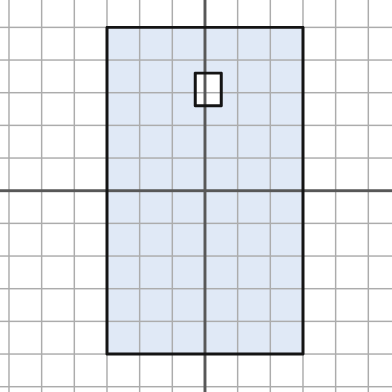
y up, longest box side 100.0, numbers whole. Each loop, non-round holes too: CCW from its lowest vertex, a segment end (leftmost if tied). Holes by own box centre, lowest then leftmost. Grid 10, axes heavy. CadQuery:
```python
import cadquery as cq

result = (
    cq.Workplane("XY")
    .moveTo(-30.0, -50.0)
    .lineTo(30.0, -50.0)
    .lineTo(30.0, 50.0)
    .lineTo(-30.0, 50.0)
    .close()
    .moveTo(-3.0, 26.0)
    .lineTo(5.0, 26.0)
    .lineTo(5.0, 36.0)
    .lineTo(-3.0, 36.0)
    .close()
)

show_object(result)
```